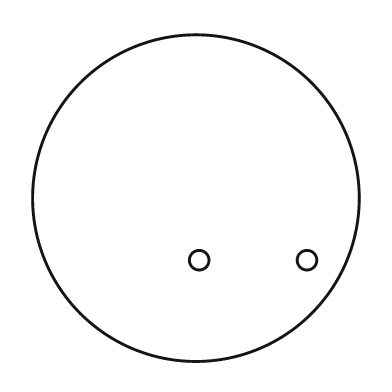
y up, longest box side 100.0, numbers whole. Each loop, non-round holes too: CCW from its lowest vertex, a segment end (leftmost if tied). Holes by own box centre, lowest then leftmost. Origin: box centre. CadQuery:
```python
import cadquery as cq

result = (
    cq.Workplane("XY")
    .moveTo(0.0, 0.0)
    .circle(50.0)
    .moveTo(1.0, -19.0)
    .circle(3.0)
    .moveTo(34.0, -19.0)
    .circle(3.0)
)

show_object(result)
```